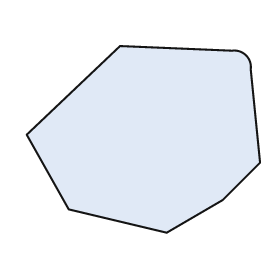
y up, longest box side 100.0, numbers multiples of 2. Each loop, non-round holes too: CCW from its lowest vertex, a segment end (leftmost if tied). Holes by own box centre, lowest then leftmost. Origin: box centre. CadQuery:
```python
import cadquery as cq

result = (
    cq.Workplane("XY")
    .moveTo(10.0, -40.0)
    .lineTo(34.0, -26.0)
    .lineTo(50.0, -10.0)
    .lineTo(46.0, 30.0)
    .threePointArc((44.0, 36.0), (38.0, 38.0))
    .lineTo(-10.0, 40.0)
    .lineTo(-50.0, 2.0)
    .lineTo(-32.0, -30.0)
    .close()
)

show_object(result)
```